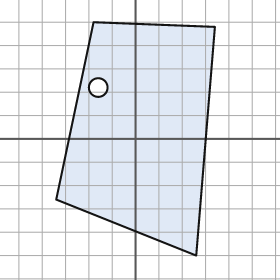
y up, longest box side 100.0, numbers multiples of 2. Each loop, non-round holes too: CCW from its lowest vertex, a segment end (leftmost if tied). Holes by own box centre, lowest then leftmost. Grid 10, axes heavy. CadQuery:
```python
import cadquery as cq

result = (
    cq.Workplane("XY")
    .moveTo(26.0, -50.0)
    .lineTo(34.0, 48.0)
    .lineTo(-18.0, 50.0)
    .lineTo(-34.0, -26.0)
    .close()
    .moveTo(-16.0, 22.0)
    .circle(4.0)
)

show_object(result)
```